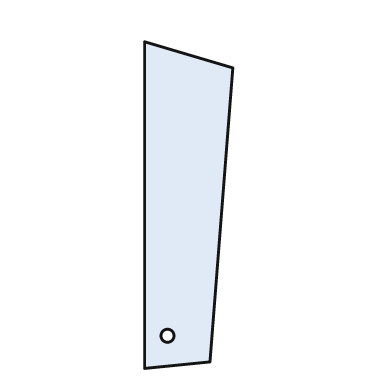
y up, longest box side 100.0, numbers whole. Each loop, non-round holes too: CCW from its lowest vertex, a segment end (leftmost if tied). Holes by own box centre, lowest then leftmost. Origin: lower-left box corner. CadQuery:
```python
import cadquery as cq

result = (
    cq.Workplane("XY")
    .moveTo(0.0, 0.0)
    .lineTo(20.0, 2.0)
    .lineTo(27.0, 92.0)
    .lineTo(0.0, 100.0)
    .close()
    .moveTo(7.0, 10.0)
    .circle(2.0)
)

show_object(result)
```